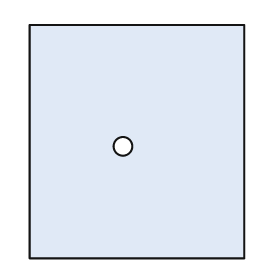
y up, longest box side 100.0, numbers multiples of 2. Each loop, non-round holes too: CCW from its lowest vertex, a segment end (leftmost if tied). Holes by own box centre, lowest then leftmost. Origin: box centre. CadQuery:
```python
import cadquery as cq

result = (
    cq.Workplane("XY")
    .moveTo(-46.0, -50.0)
    .lineTo(46.0, -50.0)
    .lineTo(46.0, 50.0)
    .lineTo(-46.0, 50.0)
    .close()
    .moveTo(-6.0, -2.0)
    .circle(4.0)
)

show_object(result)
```